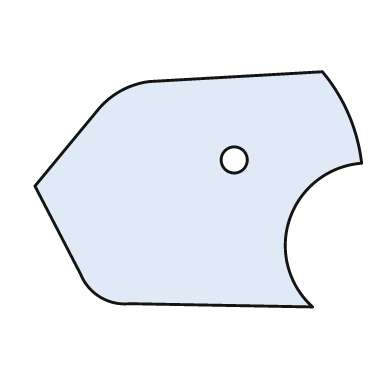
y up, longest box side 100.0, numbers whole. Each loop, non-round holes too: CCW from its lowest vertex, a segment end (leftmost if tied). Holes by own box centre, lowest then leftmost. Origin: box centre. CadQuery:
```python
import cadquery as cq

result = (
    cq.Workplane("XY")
    .moveTo(35.0, -36.0)
    .threePointArc((28.0, -9.0), (50.0, 8.0))
    .threePointArc((46.0, 23.0), (38.0, 36.0))
    .lineTo(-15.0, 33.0)
    .threePointArc((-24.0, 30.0), (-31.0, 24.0))
    .lineTo(-50.0, 1.0)
    .lineTo(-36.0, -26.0)
    .threePointArc((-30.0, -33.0), (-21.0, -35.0))
    .close()
    .moveTo(11.0, 9.0)
    .circle(4.0)
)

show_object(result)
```